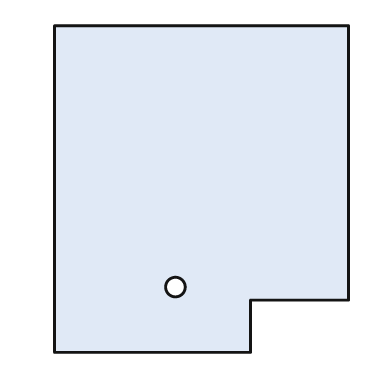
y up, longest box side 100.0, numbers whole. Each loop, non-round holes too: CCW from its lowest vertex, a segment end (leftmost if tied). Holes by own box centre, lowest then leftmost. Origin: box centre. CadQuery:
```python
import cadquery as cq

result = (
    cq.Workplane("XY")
    .moveTo(-45.0, -50.0)
    .lineTo(15.0, -50.0)
    .lineTo(15.0, -34.0)
    .lineTo(45.0, -34.0)
    .lineTo(45.0, 50.0)
    .lineTo(-45.0, 50.0)
    .close()
    .moveTo(-8.0, -30.0)
    .circle(3.0)
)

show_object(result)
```